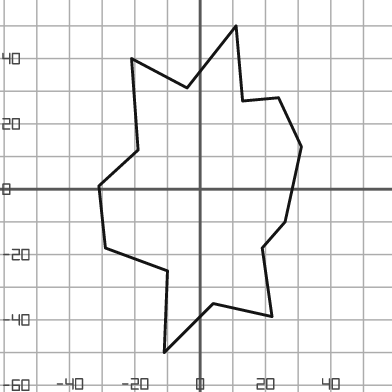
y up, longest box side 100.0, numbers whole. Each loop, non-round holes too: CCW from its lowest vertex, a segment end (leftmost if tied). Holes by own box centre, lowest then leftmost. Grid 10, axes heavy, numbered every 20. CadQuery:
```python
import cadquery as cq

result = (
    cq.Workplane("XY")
    .moveTo(-11.0, -50.0)
    .lineTo(4.0, -35.0)
    .lineTo(22.0, -39.0)
    .lineTo(19.0, -18.0)
    .lineTo(26.0, -10.0)
    .lineTo(31.0, 13.0)
    .lineTo(24.0, 28.0)
    .lineTo(13.0, 27.0)
    .lineTo(11.0, 50.0)
    .lineTo(-4.0, 31.0)
    .lineTo(-21.0, 40.0)
    .lineTo(-19.0, 12.0)
    .lineTo(-31.0, 1.0)
    .lineTo(-29.0, -18.0)
    .lineTo(-10.0, -25.0)
    .close()
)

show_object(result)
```